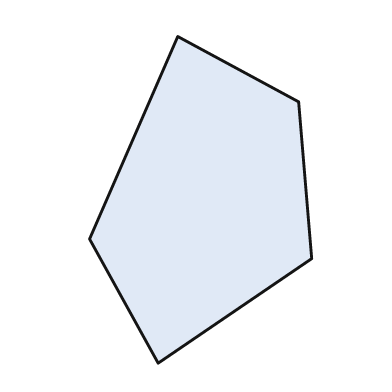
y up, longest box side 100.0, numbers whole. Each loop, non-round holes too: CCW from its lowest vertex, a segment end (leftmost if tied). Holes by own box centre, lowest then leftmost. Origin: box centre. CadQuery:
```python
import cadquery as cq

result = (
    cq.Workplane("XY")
    .moveTo(-13.0, -50.0)
    .lineTo(34.0, -18.0)
    .lineTo(30.0, 30.0)
    .lineTo(-7.0, 50.0)
    .lineTo(-34.0, -12.0)
    .close()
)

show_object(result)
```